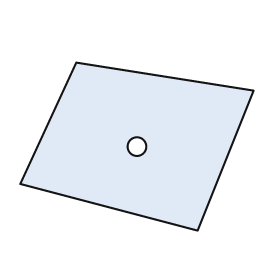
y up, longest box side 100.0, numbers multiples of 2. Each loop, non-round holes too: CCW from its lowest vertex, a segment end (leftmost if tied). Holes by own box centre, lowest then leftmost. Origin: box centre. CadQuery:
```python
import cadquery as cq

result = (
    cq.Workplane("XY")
    .moveTo(26.0, -36.0)
    .lineTo(50.0, 24.0)
    .lineTo(-26.0, 36.0)
    .lineTo(-50.0, -16.0)
    .close()
    .moveTo(0.0, 0.0)
    .circle(4.0)
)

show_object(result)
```